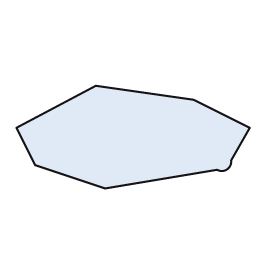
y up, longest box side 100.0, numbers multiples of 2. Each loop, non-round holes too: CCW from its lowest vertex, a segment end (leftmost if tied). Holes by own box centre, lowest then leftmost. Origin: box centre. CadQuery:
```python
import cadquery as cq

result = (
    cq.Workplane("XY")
    .moveTo(-12.0, -22.0)
    .lineTo(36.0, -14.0)
    .threePointArc((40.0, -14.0), (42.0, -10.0))
    .lineTo(50.0, 4.0)
    .lineTo(26.0, 16.0)
    .lineTo(-16.0, 22.0)
    .lineTo(-50.0, 4.0)
    .lineTo(-42.0, -12.0)
    .close()
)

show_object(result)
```